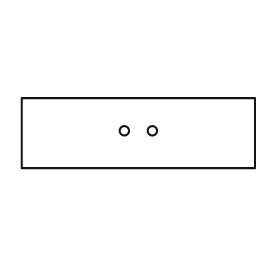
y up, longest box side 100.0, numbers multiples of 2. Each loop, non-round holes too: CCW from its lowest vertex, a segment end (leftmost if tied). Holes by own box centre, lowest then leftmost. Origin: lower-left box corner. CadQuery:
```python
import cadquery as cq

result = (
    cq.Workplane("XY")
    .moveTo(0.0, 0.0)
    .lineTo(100.0, 0.0)
    .lineTo(100.0, 30.0)
    .lineTo(0.0, 30.0)
    .close()
    .moveTo(44.0, 16.0)
    .circle(2.0)
    .moveTo(56.0, 16.0)
    .circle(2.0)
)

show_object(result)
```